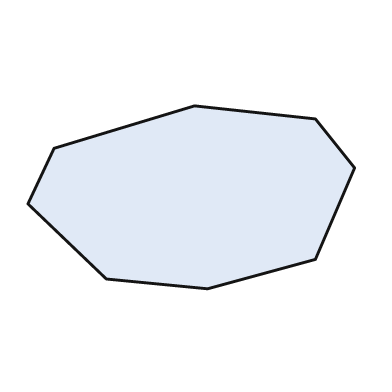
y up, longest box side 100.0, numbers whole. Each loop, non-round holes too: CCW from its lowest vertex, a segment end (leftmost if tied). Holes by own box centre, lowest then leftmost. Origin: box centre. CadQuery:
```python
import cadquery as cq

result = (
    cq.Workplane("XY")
    .moveTo(5.0, -28.0)
    .lineTo(38.0, -19.0)
    .lineTo(50.0, 9.0)
    .lineTo(38.0, 24.0)
    .lineTo(1.0, 28.0)
    .lineTo(-42.0, 15.0)
    .lineTo(-50.0, -2.0)
    .lineTo(-26.0, -25.0)
    .close()
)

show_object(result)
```